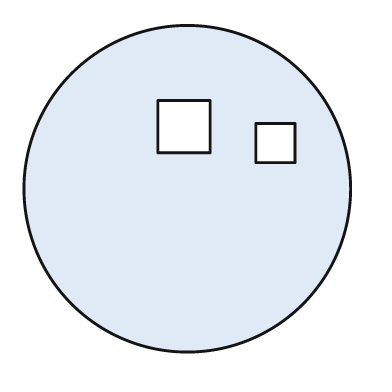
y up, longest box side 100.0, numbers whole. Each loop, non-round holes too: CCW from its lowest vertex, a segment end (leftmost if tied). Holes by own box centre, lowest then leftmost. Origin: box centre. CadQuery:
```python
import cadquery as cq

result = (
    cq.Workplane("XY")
    .moveTo(0.0, 0.0)
    .circle(50.0)
    .moveTo(21.0, 8.0)
    .lineTo(33.0, 8.0)
    .lineTo(33.0, 20.0)
    .lineTo(21.0, 20.0)
    .close()
    .moveTo(-9.0, 11.0)
    .lineTo(7.0, 11.0)
    .lineTo(7.0, 27.0)
    .lineTo(-9.0, 27.0)
    .close()
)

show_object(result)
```